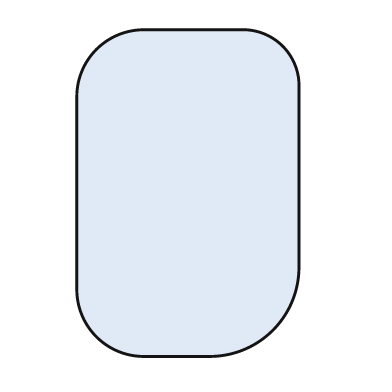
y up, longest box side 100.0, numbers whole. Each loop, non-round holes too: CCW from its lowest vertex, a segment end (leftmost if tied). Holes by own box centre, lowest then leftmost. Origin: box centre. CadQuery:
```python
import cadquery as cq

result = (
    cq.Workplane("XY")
    .moveTo(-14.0, -50.0)
    .lineTo(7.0, -50.0)
    .threePointArc((26.0, -42.0), (34.0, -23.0))
    .lineTo(34.0, 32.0)
    .threePointArc((29.0, 45.0), (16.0, 50.0))
    .lineTo(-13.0, 50.0)
    .threePointArc((-28.0, 44.0), (-34.0, 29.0))
    .lineTo(-34.0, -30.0)
    .threePointArc((-28.0, -44.0), (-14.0, -50.0))
    .close()
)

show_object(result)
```